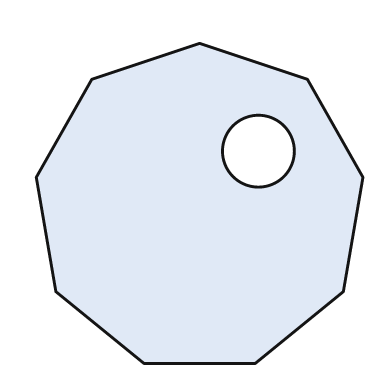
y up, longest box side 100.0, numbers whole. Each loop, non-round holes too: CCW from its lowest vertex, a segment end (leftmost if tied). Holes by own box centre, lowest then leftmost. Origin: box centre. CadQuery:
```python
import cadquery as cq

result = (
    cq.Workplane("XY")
    .moveTo(-17.0, -49.0)
    .lineTo(17.0, -49.0)
    .lineTo(44.0, -27.0)
    .lineTo(50.0, 8.0)
    .lineTo(33.0, 38.0)
    .lineTo(0.0, 49.0)
    .lineTo(-33.0, 38.0)
    .lineTo(-50.0, 8.0)
    .lineTo(-44.0, -27.0)
    .close()
    .moveTo(18.0, 16.0)
    .circle(11.0)
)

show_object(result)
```